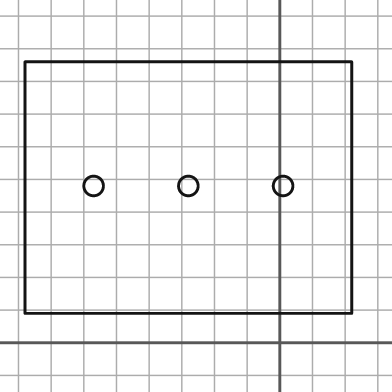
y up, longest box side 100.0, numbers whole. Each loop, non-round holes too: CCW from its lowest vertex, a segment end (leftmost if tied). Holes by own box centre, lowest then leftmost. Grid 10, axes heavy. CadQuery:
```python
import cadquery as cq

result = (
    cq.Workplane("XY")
    .moveTo(-78.0, 9.0)
    .lineTo(22.0, 9.0)
    .lineTo(22.0, 86.0)
    .lineTo(-78.0, 86.0)
    .close()
    .moveTo(-57.0, 48.0)
    .circle(3.0)
    .moveTo(-28.0, 48.0)
    .circle(3.0)
    .moveTo(1.0, 48.0)
    .circle(3.0)
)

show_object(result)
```